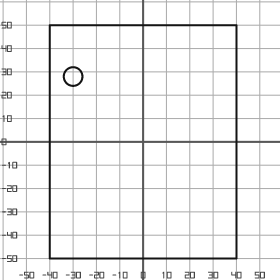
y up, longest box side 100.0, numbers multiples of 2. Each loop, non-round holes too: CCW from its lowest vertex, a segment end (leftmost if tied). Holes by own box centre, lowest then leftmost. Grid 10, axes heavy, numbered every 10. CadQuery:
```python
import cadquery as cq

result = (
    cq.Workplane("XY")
    .moveTo(-40.0, -50.0)
    .lineTo(40.0, -50.0)
    .lineTo(40.0, 50.0)
    .lineTo(-40.0, 50.0)
    .close()
    .moveTo(-30.0, 28.0)
    .circle(4.0)
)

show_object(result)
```